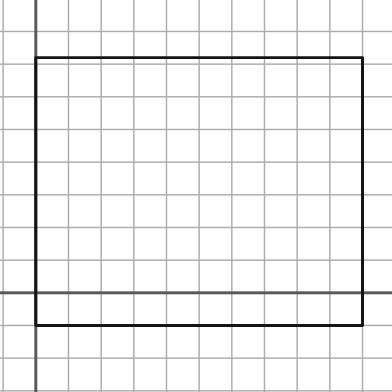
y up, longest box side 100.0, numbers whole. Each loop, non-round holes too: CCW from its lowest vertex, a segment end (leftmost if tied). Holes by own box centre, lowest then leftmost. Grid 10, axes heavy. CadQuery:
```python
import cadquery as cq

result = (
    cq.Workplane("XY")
    .moveTo(0.0, -10.0)
    .lineTo(100.0, -10.0)
    .lineTo(100.0, 72.0)
    .lineTo(0.0, 72.0)
    .close()
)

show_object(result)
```